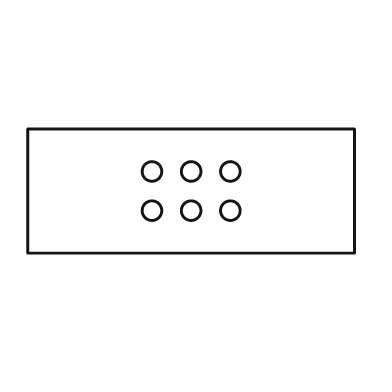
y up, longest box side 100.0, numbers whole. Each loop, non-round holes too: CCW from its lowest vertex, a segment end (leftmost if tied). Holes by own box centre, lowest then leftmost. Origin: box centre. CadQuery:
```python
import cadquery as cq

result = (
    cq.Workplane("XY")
    .moveTo(-50.0, -19.0)
    .lineTo(50.0, -19.0)
    .lineTo(50.0, 19.0)
    .lineTo(-50.0, 19.0)
    .close()
    .moveTo(-12.0, -6.0)
    .circle(3.0)
    .moveTo(0.0, -6.0)
    .circle(3.0)
    .moveTo(12.0, -6.0)
    .circle(3.0)
    .moveTo(-12.0, 6.0)
    .circle(3.0)
    .moveTo(0.0, 6.0)
    .circle(3.0)
    .moveTo(12.0, 6.0)
    .circle(3.0)
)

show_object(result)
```